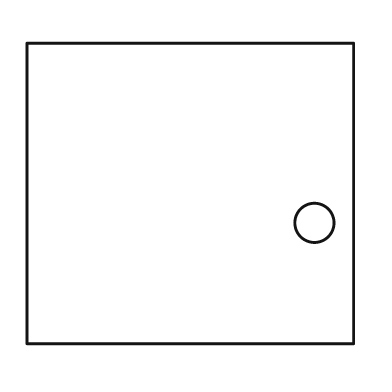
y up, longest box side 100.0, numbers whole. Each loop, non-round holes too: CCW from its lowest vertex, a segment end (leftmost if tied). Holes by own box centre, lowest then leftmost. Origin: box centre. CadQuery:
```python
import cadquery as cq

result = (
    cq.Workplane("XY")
    .moveTo(-50.0, -46.0)
    .lineTo(50.0, -46.0)
    .lineTo(50.0, 46.0)
    .lineTo(-50.0, 46.0)
    .close()
    .moveTo(38.0, -9.0)
    .circle(6.0)
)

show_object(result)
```